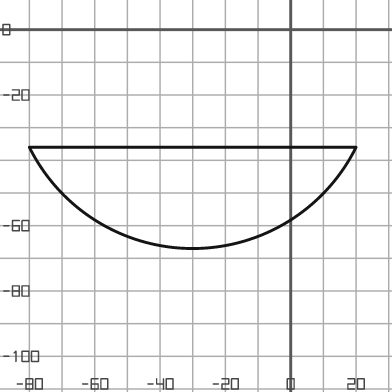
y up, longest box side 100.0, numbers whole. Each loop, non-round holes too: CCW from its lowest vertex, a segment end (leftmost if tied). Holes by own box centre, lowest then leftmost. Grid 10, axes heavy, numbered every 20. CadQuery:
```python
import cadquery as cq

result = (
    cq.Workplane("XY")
    .moveTo(-80.0, -36.0)
    .threePointArc((-30.0, -67.0), (20.0, -36.0))
    .close()
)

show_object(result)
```